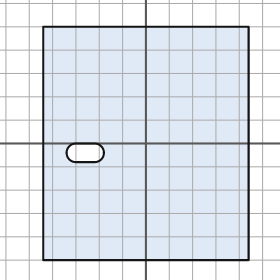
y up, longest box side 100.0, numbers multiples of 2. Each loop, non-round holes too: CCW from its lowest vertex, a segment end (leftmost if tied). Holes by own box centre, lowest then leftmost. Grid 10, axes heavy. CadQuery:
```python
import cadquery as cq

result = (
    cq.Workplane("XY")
    .moveTo(-44.0, -50.0)
    .lineTo(44.0, -50.0)
    .lineTo(44.0, 50.0)
    .lineTo(-44.0, 50.0)
    .close()
    .moveTo(-30.0, -8.0)
    .lineTo(-22.0, -8.0)
    .threePointArc((-18.0, -4.0), (-22.0, 0.0))
    .lineTo(-30.0, 0.0)
    .threePointArc((-34.0, -4.0), (-30.0, -8.0))
    .close()
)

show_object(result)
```